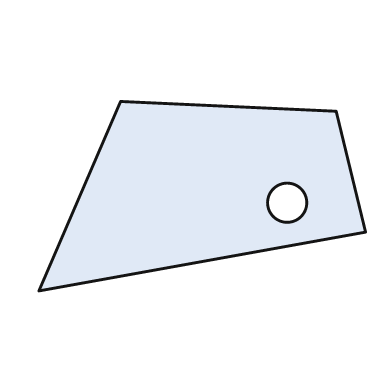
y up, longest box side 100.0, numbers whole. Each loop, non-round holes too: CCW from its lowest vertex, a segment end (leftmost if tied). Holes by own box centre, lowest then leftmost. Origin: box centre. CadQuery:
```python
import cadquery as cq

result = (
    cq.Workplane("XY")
    .moveTo(-50.0, -29.0)
    .lineTo(50.0, -11.0)
    .lineTo(41.0, 26.0)
    .lineTo(-25.0, 29.0)
    .close()
    .moveTo(26.0, -2.0)
    .circle(6.0)
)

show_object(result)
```